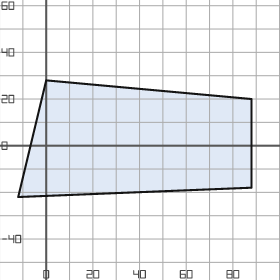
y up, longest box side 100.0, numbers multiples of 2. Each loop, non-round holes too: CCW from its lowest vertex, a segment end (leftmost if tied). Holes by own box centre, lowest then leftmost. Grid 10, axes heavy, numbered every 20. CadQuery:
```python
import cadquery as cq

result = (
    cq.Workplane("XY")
    .moveTo(-12.0, -22.0)
    .lineTo(88.0, -18.0)
    .lineTo(88.0, 20.0)
    .lineTo(0.0, 28.0)
    .close()
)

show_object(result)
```